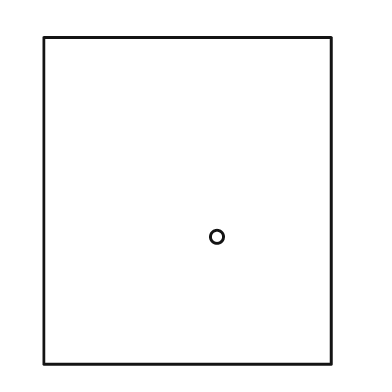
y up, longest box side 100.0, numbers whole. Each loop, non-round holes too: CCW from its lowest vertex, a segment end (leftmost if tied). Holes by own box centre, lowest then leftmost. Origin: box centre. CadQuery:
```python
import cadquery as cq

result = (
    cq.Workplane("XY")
    .moveTo(-44.0, -50.0)
    .lineTo(44.0, -50.0)
    .lineTo(44.0, 50.0)
    .lineTo(-44.0, 50.0)
    .close()
    .moveTo(9.0, -11.0)
    .circle(2.0)
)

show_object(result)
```